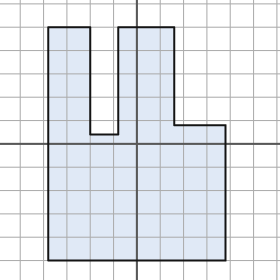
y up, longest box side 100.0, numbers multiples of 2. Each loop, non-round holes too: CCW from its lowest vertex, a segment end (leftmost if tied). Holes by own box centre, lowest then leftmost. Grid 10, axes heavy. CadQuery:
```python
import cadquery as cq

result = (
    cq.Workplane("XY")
    .moveTo(-38.0, -50.0)
    .lineTo(38.0, -50.0)
    .lineTo(38.0, 8.0)
    .lineTo(16.0, 8.0)
    .lineTo(16.0, 50.0)
    .lineTo(-8.0, 50.0)
    .lineTo(-8.0, 4.0)
    .lineTo(-20.0, 4.0)
    .lineTo(-20.0, 50.0)
    .lineTo(-38.0, 50.0)
    .close()
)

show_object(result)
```